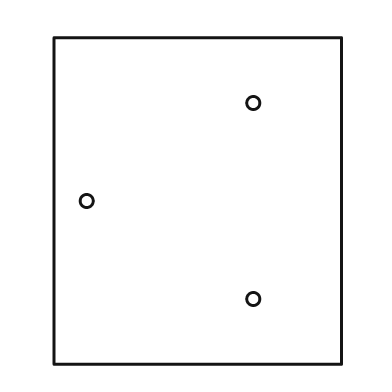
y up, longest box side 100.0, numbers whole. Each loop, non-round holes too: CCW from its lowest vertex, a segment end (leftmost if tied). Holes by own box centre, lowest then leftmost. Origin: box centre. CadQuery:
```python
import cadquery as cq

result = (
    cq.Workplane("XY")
    .moveTo(-44.0, -50.0)
    .lineTo(44.0, -50.0)
    .lineTo(44.0, 50.0)
    .lineTo(-44.0, 50.0)
    .close()
    .moveTo(17.0, -30.0)
    .circle(2.0)
    .moveTo(-34.0, 0.0)
    .circle(2.0)
    .moveTo(17.0, 30.0)
    .circle(2.0)
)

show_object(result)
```